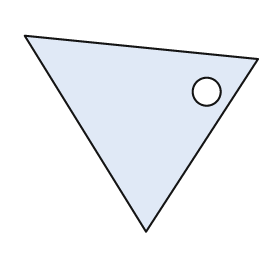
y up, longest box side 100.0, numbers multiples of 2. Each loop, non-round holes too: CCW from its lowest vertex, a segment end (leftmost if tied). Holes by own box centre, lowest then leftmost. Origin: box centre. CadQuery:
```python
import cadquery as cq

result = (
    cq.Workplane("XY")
    .moveTo(2.0, -42.0)
    .lineTo(50.0, 32.0)
    .lineTo(-50.0, 42.0)
    .close()
    .moveTo(28.0, 18.0)
    .circle(6.0)
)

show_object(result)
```